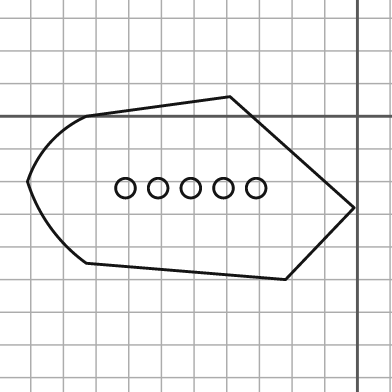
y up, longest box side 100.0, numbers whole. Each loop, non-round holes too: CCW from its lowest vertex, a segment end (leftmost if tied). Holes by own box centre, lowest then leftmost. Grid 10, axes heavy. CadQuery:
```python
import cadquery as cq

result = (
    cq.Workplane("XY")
    .moveTo(-22.0, -50.0)
    .lineTo(-1.0, -28.0)
    .lineTo(-39.0, 6.0)
    .lineTo(-83.0, 0.0)
    .threePointArc((-94.0, -8.0), (-101.0, -20.0))
    .threePointArc((-94.0, -34.0), (-83.0, -45.0))
    .close()
    .moveTo(-71.0, -22.0)
    .circle(3.0)
    .moveTo(-61.0, -22.0)
    .circle(3.0)
    .moveTo(-51.0, -22.0)
    .circle(3.0)
    .moveTo(-41.0, -22.0)
    .circle(3.0)
    .moveTo(-31.0, -22.0)
    .circle(3.0)
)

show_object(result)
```